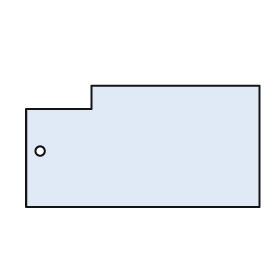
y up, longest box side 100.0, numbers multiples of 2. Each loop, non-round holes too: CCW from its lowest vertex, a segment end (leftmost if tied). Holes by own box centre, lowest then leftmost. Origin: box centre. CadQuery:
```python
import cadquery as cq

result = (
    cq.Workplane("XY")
    .moveTo(-50.0, -26.0)
    .lineTo(50.0, -26.0)
    .lineTo(50.0, 26.0)
    .lineTo(-22.0, 26.0)
    .lineTo(-22.0, 16.0)
    .lineTo(-50.0, 16.0)
    .close()
    .moveTo(-44.0, -2.0)
    .circle(2.0)
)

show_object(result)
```